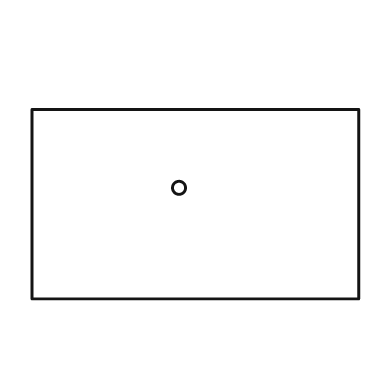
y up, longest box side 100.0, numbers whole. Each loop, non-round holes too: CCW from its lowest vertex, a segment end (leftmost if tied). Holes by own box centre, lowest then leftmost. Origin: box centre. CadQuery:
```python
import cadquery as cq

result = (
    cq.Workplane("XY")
    .moveTo(-50.0, -29.0)
    .lineTo(50.0, -29.0)
    .lineTo(50.0, 29.0)
    .lineTo(-50.0, 29.0)
    .close()
    .moveTo(-5.0, 5.0)
    .circle(2.0)
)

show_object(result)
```